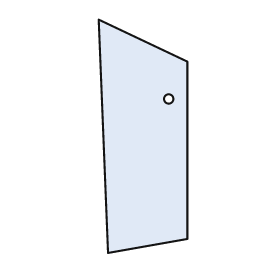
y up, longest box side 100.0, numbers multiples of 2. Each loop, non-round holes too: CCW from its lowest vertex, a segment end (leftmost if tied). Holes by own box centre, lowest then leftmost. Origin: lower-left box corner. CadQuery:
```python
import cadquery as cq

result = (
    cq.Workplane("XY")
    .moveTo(4.0, 0.0)
    .lineTo(38.0, 6.0)
    .lineTo(38.0, 82.0)
    .lineTo(0.0, 100.0)
    .close()
    .moveTo(30.0, 66.0)
    .circle(2.0)
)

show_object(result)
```